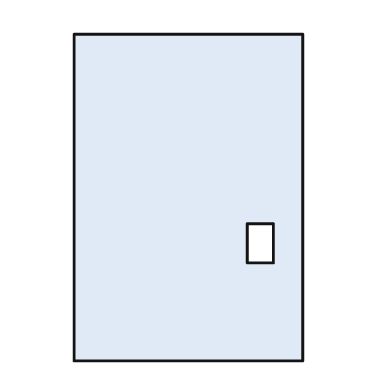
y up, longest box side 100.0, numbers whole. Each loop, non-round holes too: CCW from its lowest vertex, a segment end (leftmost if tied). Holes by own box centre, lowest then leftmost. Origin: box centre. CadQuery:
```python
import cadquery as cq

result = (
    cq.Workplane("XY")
    .moveTo(-35.0, -50.0)
    .lineTo(35.0, -50.0)
    .lineTo(35.0, 50.0)
    .lineTo(-35.0, 50.0)
    .close()
    .moveTo(18.0, -20.0)
    .lineTo(26.0, -20.0)
    .lineTo(26.0, -8.0)
    .lineTo(18.0, -8.0)
    .close()
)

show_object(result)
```